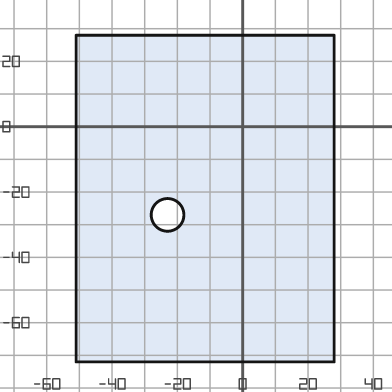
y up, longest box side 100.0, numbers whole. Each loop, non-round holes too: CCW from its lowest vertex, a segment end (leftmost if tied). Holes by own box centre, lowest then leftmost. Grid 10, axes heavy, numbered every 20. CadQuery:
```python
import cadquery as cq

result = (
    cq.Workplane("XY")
    .moveTo(-51.0, -72.0)
    .lineTo(28.0, -72.0)
    .lineTo(28.0, 28.0)
    .lineTo(-51.0, 28.0)
    .close()
    .moveTo(-23.0, -27.0)
    .circle(5.0)
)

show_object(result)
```